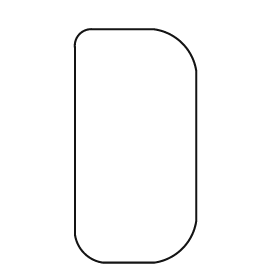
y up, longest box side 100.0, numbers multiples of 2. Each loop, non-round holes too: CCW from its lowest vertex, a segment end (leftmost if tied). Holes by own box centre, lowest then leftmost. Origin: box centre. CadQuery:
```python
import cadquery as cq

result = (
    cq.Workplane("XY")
    .moveTo(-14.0, -50.0)
    .lineTo(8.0, -50.0)
    .threePointArc((20.0, -44.0), (26.0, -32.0))
    .lineTo(26.0, 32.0)
    .threePointArc((20.0, 44.0), (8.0, 50.0))
    .lineTo(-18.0, 50.0)
    .threePointArc((-24.0, 48.0), (-26.0, 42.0))
    .lineTo(-26.0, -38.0)
    .threePointArc((-22.0, -46.0), (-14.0, -50.0))
    .close()
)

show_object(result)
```